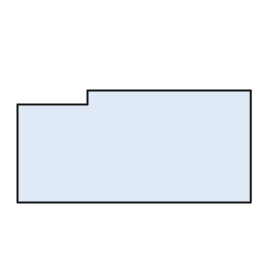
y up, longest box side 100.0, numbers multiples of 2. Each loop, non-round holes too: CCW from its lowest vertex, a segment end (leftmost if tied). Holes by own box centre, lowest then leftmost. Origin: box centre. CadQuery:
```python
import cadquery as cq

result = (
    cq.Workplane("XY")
    .moveTo(-50.0, -24.0)
    .lineTo(50.0, -24.0)
    .lineTo(50.0, 24.0)
    .lineTo(-20.0, 24.0)
    .lineTo(-20.0, 18.0)
    .lineTo(-50.0, 18.0)
    .close()
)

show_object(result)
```